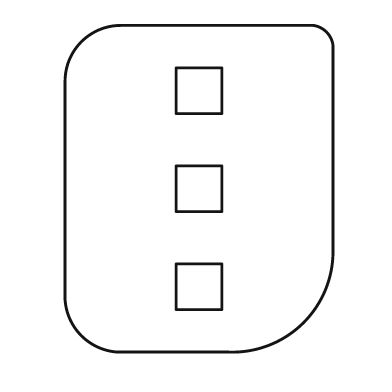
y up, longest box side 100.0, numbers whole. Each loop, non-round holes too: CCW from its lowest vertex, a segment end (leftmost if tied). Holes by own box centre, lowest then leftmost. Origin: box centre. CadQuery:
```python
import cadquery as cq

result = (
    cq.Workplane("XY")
    .moveTo(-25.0, -50.0)
    .lineTo(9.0, -50.0)
    .threePointArc((32.0, -41.0), (41.0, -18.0))
    .lineTo(41.0, 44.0)
    .threePointArc((39.0, 48.0), (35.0, 50.0))
    .lineTo(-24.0, 50.0)
    .threePointArc((-36.0, 45.0), (-41.0, 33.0))
    .lineTo(-41.0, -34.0)
    .threePointArc((-36.0, -45.0), (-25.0, -50.0))
    .close()
    .moveTo(-7.0, -37.0)
    .lineTo(7.0, -37.0)
    .lineTo(7.0, -23.0)
    .lineTo(-7.0, -23.0)
    .close()
    .moveTo(-7.0, -7.0)
    .lineTo(7.0, -7.0)
    .lineTo(7.0, 7.0)
    .lineTo(-7.0, 7.0)
    .close()
    .moveTo(-7.0, 23.0)
    .lineTo(7.0, 23.0)
    .lineTo(7.0, 37.0)
    .lineTo(-7.0, 37.0)
    .close()
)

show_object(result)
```